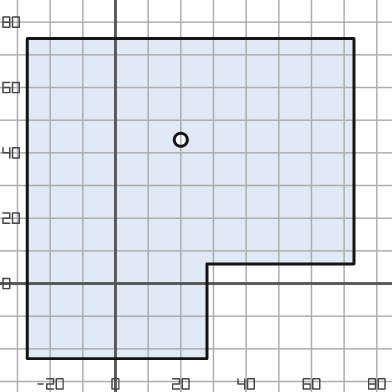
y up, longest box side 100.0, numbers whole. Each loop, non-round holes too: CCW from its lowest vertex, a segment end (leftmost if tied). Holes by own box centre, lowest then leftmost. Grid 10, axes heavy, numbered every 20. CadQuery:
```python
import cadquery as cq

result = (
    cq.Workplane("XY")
    .moveTo(-27.0, -23.0)
    .lineTo(28.0, -23.0)
    .lineTo(28.0, 6.0)
    .lineTo(73.0, 6.0)
    .lineTo(73.0, 75.0)
    .lineTo(-27.0, 75.0)
    .close()
    .moveTo(20.0, 44.0)
    .circle(2.0)
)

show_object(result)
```